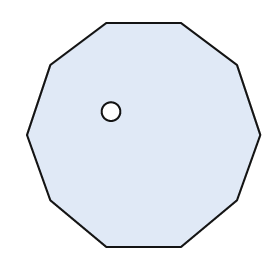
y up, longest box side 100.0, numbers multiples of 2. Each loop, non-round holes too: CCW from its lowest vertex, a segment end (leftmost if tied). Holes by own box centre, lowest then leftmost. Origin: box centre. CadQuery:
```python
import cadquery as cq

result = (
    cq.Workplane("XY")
    .moveTo(-16.0, -48.0)
    .lineTo(16.0, -48.0)
    .lineTo(40.0, -28.0)
    .lineTo(50.0, 0.0)
    .lineTo(40.0, 30.0)
    .lineTo(16.0, 48.0)
    .lineTo(-16.0, 48.0)
    .lineTo(-40.0, 30.0)
    .lineTo(-50.0, 0.0)
    .lineTo(-40.0, -28.0)
    .close()
    .moveTo(-14.0, 10.0)
    .circle(4.0)
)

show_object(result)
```